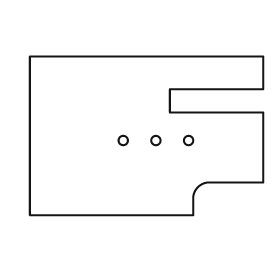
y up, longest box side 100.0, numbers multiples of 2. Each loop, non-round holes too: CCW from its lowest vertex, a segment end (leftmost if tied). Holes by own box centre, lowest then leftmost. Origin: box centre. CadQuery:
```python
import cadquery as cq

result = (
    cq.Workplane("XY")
    .moveTo(-50.0, -34.0)
    .lineTo(20.0, -34.0)
    .lineTo(20.0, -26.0)
    .threePointArc((22.0, -22.0), (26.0, -20.0))
    .lineTo(50.0, -20.0)
    .lineTo(50.0, 10.0)
    .lineTo(10.0, 10.0)
    .lineTo(10.0, 20.0)
    .lineTo(50.0, 20.0)
    .lineTo(50.0, 34.0)
    .lineTo(-50.0, 34.0)
    .close()
    .moveTo(-10.0, -2.0)
    .circle(2.0)
    .moveTo(4.0, -2.0)
    .circle(2.0)
    .moveTo(18.0, -2.0)
    .circle(2.0)
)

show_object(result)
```